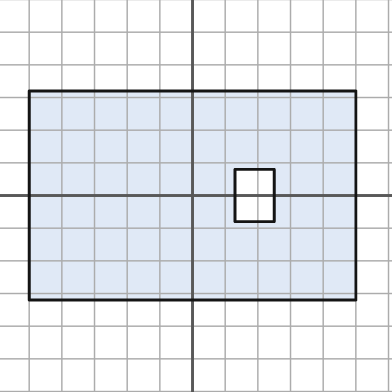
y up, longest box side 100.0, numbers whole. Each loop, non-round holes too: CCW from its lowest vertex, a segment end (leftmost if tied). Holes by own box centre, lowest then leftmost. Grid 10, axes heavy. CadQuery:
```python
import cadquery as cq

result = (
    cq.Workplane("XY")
    .moveTo(-50.0, -32.0)
    .lineTo(50.0, -32.0)
    .lineTo(50.0, 32.0)
    .lineTo(-50.0, 32.0)
    .close()
    .moveTo(13.0, -8.0)
    .lineTo(25.0, -8.0)
    .lineTo(25.0, 8.0)
    .lineTo(13.0, 8.0)
    .close()
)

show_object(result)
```